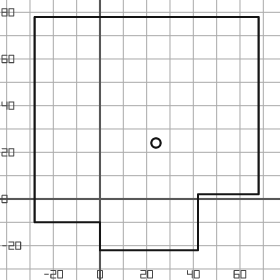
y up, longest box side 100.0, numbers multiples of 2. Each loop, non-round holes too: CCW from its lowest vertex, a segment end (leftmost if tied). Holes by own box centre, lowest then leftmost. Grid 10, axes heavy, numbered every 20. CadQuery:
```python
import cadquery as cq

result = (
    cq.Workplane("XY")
    .moveTo(0.0, -22.0)
    .lineTo(42.0, -22.0)
    .lineTo(42.0, 2.0)
    .lineTo(68.0, 2.0)
    .lineTo(68.0, 78.0)
    .lineTo(-28.0, 78.0)
    .lineTo(-28.0, -10.0)
    .lineTo(0.0, -10.0)
    .close()
    .moveTo(24.0, 24.0)
    .circle(2.0)
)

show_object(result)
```